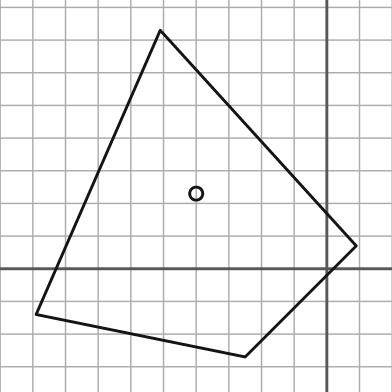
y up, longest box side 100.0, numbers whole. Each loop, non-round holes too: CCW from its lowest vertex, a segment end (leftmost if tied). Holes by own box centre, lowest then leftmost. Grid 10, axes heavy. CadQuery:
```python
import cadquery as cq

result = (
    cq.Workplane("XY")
    .moveTo(-25.0, -27.0)
    .lineTo(9.0, 7.0)
    .lineTo(-51.0, 73.0)
    .lineTo(-89.0, -14.0)
    .close()
    .moveTo(-40.0, 23.0)
    .circle(2.0)
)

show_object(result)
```